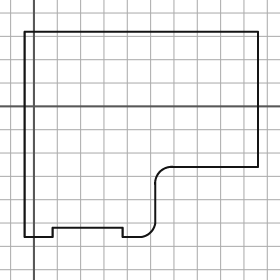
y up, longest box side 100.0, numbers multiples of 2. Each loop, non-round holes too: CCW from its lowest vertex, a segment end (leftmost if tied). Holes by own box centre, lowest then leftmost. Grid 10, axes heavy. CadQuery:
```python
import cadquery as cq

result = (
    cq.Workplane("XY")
    .moveTo(-4.0, -56.0)
    .lineTo(8.0, -56.0)
    .lineTo(8.0, -52.0)
    .lineTo(38.0, -52.0)
    .lineTo(38.0, -56.0)
    .lineTo(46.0, -56.0)
    .threePointArc((50.0, -54.0), (52.0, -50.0))
    .lineTo(52.0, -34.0)
    .threePointArc((54.0, -28.0), (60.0, -26.0))
    .lineTo(96.0, -26.0)
    .lineTo(96.0, 32.0)
    .lineTo(-4.0, 32.0)
    .close()
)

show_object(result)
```